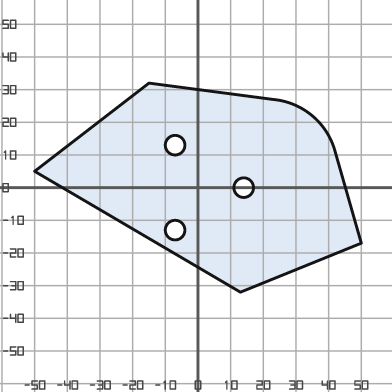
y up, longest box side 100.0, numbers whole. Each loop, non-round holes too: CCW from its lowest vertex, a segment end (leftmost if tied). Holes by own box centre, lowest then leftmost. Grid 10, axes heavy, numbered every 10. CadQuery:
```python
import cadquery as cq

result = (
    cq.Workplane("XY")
    .moveTo(13.0, -32.0)
    .lineTo(50.0, -17.0)
    .lineTo(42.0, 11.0)
    .threePointArc((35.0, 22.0), (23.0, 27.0))
    .lineTo(-15.0, 32.0)
    .lineTo(-50.0, 5.0)
    .close()
    .moveTo(-7.0, -13.0)
    .circle(3.0)
    .moveTo(14.0, 0.0)
    .circle(3.0)
    .moveTo(-7.0, 13.0)
    .circle(3.0)
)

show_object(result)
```